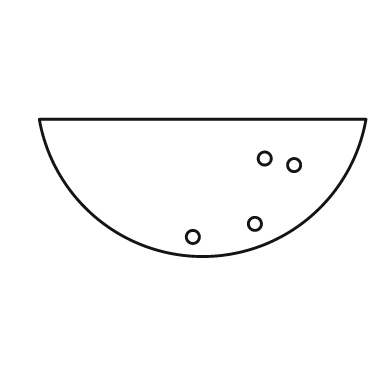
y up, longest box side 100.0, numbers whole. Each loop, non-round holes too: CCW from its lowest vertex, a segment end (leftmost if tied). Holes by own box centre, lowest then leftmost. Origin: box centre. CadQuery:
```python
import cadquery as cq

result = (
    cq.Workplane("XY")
    .moveTo(-50.0, 21.0)
    .threePointArc((0.0, -21.0), (50.0, 21.0))
    .close()
    .moveTo(-3.0, -15.0)
    .circle(2.0)
    .moveTo(16.0, -11.0)
    .circle(2.0)
    .moveTo(28.0, 7.0)
    .circle(2.0)
    .moveTo(19.0, 9.0)
    .circle(2.0)
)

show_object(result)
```